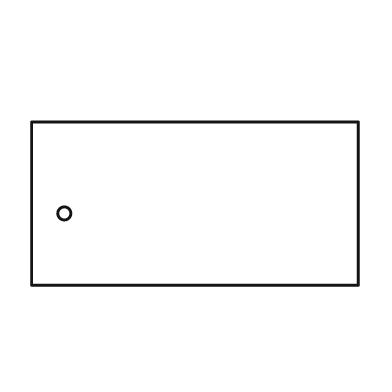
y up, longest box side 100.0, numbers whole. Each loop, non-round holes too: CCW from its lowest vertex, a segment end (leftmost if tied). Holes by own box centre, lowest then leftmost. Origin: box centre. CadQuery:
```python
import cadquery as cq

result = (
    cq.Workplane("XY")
    .moveTo(-50.0, -25.0)
    .lineTo(50.0, -25.0)
    .lineTo(50.0, 25.0)
    .lineTo(-50.0, 25.0)
    .close()
    .moveTo(-40.0, -3.0)
    .circle(2.0)
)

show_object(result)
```